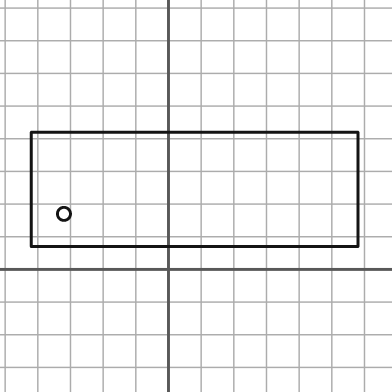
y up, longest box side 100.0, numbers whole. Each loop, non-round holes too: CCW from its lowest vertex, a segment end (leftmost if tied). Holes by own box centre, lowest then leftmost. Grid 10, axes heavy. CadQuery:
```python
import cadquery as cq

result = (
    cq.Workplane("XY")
    .moveTo(-42.0, 7.0)
    .lineTo(58.0, 7.0)
    .lineTo(58.0, 42.0)
    .lineTo(-42.0, 42.0)
    .close()
    .moveTo(-32.0, 17.0)
    .circle(2.0)
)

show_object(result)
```